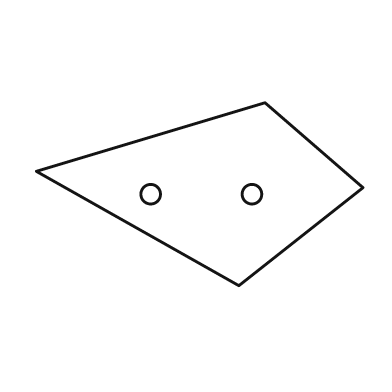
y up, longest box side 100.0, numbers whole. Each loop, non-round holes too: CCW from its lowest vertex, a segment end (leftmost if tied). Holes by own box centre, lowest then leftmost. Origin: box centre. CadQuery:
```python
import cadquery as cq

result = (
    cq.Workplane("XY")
    .moveTo(12.0, -28.0)
    .lineTo(50.0, 2.0)
    .lineTo(20.0, 28.0)
    .lineTo(-50.0, 7.0)
    .close()
    .moveTo(-15.0, 0.0)
    .circle(3.0)
    .moveTo(16.0, 0.0)
    .circle(3.0)
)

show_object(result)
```